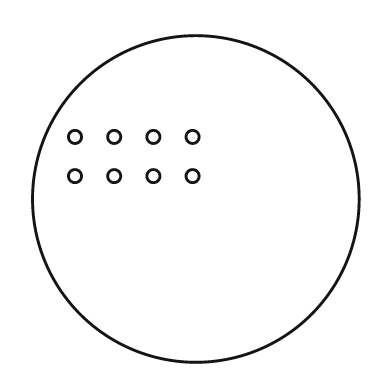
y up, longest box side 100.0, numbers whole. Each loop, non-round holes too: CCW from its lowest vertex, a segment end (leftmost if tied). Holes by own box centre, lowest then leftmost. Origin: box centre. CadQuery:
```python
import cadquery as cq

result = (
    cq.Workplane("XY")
    .moveTo(0.0, 0.0)
    .circle(50.0)
    .moveTo(-37.0, 7.0)
    .circle(2.0)
    .moveTo(-25.0, 7.0)
    .circle(2.0)
    .moveTo(-13.0, 7.0)
    .circle(2.0)
    .moveTo(-1.0, 7.0)
    .circle(2.0)
    .moveTo(-37.0, 19.0)
    .circle(2.0)
    .moveTo(-25.0, 19.0)
    .circle(2.0)
    .moveTo(-13.0, 19.0)
    .circle(2.0)
    .moveTo(-1.0, 19.0)
    .circle(2.0)
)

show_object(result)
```